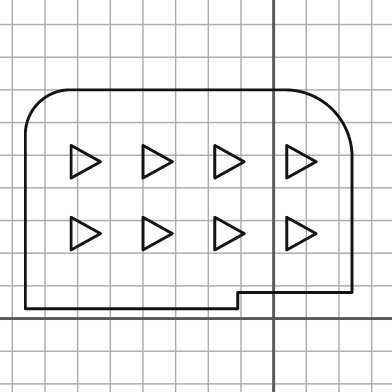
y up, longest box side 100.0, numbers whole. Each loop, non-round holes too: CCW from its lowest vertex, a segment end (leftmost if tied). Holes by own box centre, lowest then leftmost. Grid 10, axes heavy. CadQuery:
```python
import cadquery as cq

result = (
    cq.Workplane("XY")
    .moveTo(-76.0, 3.0)
    .lineTo(-11.0, 3.0)
    .lineTo(-11.0, 8.0)
    .lineTo(24.0, 8.0)
    .lineTo(24.0, 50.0)
    .threePointArc((18.0, 64.0), (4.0, 70.0))
    .lineTo(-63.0, 70.0)
    .threePointArc((-72.0, 66.0), (-76.0, 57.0))
    .close()
    .moveTo(-62.0, 21.0)
    .lineTo(-53.0, 26.0)
    .lineTo(-62.0, 31.0)
    .close()
    .moveTo(-40.0, 21.0)
    .lineTo(-31.0, 26.0)
    .lineTo(-40.0, 31.0)
    .close()
    .moveTo(-18.0, 21.0)
    .lineTo(-9.0, 26.0)
    .lineTo(-18.0, 31.0)
    .close()
    .moveTo(4.0, 21.0)
    .lineTo(13.0, 26.0)
    .lineTo(4.0, 31.0)
    .close()
    .moveTo(-62.0, 43.0)
    .lineTo(-53.0, 48.0)
    .lineTo(-62.0, 53.0)
    .close()
    .moveTo(-40.0, 43.0)
    .lineTo(-31.0, 48.0)
    .lineTo(-40.0, 53.0)
    .close()
    .moveTo(-18.0, 43.0)
    .lineTo(-9.0, 48.0)
    .lineTo(-18.0, 53.0)
    .close()
    .moveTo(4.0, 43.0)
    .lineTo(13.0, 48.0)
    .lineTo(4.0, 53.0)
    .close()
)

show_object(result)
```